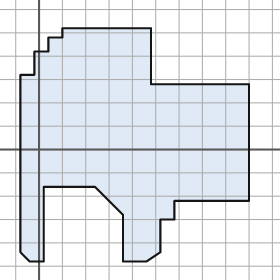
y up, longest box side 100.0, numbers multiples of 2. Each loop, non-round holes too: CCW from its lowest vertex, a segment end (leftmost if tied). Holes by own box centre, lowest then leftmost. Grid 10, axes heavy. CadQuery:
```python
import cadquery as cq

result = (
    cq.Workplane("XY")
    .moveTo(-4.0, -48.0)
    .lineTo(2.0, -48.0)
    .lineTo(2.0, -16.0)
    .lineTo(24.0, -16.0)
    .lineTo(36.0, -28.0)
    .lineTo(36.0, -48.0)
    .lineTo(46.0, -48.0)
    .lineTo(52.0, -44.0)
    .lineTo(52.0, -30.0)
    .lineTo(58.0, -30.0)
    .lineTo(58.0, -22.0)
    .lineTo(90.0, -22.0)
    .lineTo(90.0, 28.0)
    .lineTo(48.0, 28.0)
    .lineTo(48.0, 52.0)
    .lineTo(10.0, 52.0)
    .lineTo(10.0, 48.0)
    .lineTo(4.0, 48.0)
    .lineTo(4.0, 42.0)
    .lineTo(-2.0, 42.0)
    .lineTo(-2.0, 32.0)
    .lineTo(-8.0, 32.0)
    .lineTo(-8.0, -44.0)
    .close()
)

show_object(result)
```